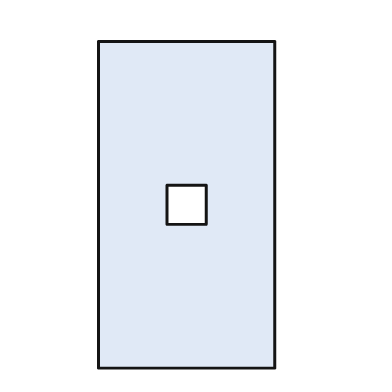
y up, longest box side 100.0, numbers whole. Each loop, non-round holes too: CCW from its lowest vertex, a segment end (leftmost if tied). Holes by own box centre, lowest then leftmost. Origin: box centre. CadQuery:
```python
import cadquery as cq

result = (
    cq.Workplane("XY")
    .moveTo(-27.0, -50.0)
    .lineTo(27.0, -50.0)
    .lineTo(27.0, 50.0)
    .lineTo(-27.0, 50.0)
    .close()
    .moveTo(-6.0, -6.0)
    .lineTo(6.0, -6.0)
    .lineTo(6.0, 6.0)
    .lineTo(-6.0, 6.0)
    .close()
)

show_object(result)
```